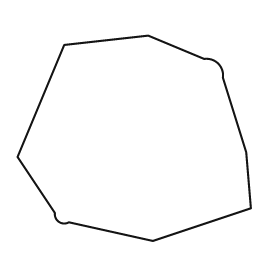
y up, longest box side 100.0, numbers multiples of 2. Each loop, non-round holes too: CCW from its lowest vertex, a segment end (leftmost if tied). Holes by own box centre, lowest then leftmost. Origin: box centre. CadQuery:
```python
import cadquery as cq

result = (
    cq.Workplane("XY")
    .moveTo(8.0, -44.0)
    .lineTo(50.0, -30.0)
    .lineTo(48.0, -6.0)
    .lineTo(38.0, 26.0)
    .threePointArc((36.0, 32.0), (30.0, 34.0))
    .lineTo(6.0, 44.0)
    .lineTo(-30.0, 40.0)
    .lineTo(-50.0, -8.0)
    .lineTo(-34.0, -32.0)
    .threePointArc((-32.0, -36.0), (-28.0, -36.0))
    .close()
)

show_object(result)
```